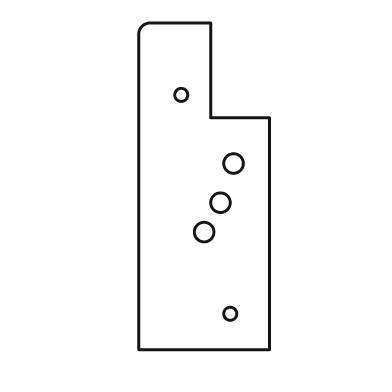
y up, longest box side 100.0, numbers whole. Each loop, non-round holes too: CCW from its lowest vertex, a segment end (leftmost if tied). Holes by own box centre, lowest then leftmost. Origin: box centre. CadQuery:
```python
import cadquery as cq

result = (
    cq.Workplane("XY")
    .moveTo(-20.0, -50.0)
    .lineTo(20.0, -50.0)
    .lineTo(20.0, 21.0)
    .lineTo(2.0, 21.0)
    .lineTo(2.0, 50.0)
    .lineTo(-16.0, 50.0)
    .threePointArc((-19.0, 49.0), (-20.0, 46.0))
    .close()
    .moveTo(8.0, -39.0)
    .circle(2.0)
    .moveTo(0.0, -14.0)
    .circle(3.0)
    .moveTo(5.0, -5.0)
    .circle(3.0)
    .moveTo(9.0, 7.0)
    .circle(3.0)
    .moveTo(-7.0, 28.0)
    .circle(2.0)
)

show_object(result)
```